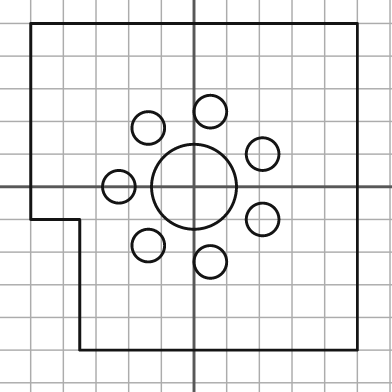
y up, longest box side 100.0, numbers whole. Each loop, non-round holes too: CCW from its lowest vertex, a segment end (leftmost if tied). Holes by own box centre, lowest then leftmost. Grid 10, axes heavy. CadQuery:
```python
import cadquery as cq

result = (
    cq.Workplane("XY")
    .moveTo(-35.0, -50.0)
    .lineTo(50.0, -50.0)
    .lineTo(50.0, 50.0)
    .lineTo(-50.0, 50.0)
    .lineTo(-50.0, -10.0)
    .lineTo(-35.0, -10.0)
    .close()
    .moveTo(5.0, -23.0)
    .circle(5.0)
    .moveTo(-14.0, -18.0)
    .circle(5.0)
    .moveTo(21.0, -10.0)
    .circle(5.0)
    .moveTo(-23.0, 0.0)
    .circle(5.0)
    .moveTo(0.0, 0.0)
    .circle(13.0)
    .moveTo(21.0, 10.0)
    .circle(5.0)
    .moveTo(-14.0, 18.0)
    .circle(5.0)
    .moveTo(5.0, 23.0)
    .circle(5.0)
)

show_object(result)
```